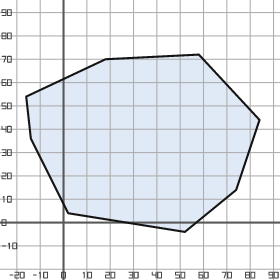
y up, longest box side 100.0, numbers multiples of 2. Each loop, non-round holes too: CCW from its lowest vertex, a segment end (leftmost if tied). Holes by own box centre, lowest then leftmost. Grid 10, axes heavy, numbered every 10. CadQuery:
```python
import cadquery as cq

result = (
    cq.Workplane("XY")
    .moveTo(52.0, -4.0)
    .lineTo(74.0, 14.0)
    .lineTo(84.0, 44.0)
    .lineTo(58.0, 72.0)
    .lineTo(18.0, 70.0)
    .lineTo(-16.0, 54.0)
    .lineTo(-14.0, 36.0)
    .lineTo(2.0, 4.0)
    .close()
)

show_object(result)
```